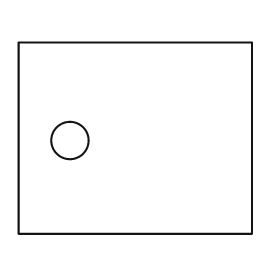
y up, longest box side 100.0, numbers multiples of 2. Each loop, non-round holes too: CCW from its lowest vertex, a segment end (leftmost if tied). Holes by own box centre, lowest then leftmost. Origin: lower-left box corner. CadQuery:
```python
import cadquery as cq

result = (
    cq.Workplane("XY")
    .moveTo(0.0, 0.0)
    .lineTo(100.0, 0.0)
    .lineTo(100.0, 82.0)
    .lineTo(0.0, 82.0)
    .close()
    .moveTo(22.0, 40.0)
    .circle(8.0)
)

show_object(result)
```